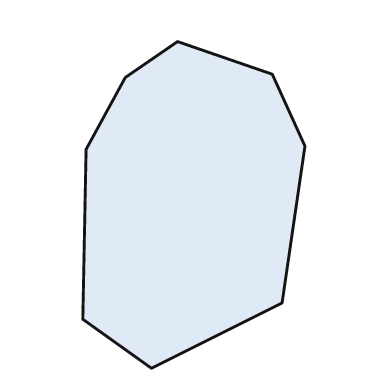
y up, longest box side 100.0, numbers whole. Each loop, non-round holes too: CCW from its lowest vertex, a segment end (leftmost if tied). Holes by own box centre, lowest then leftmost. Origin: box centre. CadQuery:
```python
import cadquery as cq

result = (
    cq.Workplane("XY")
    .moveTo(-13.0, -50.0)
    .lineTo(27.0, -30.0)
    .lineTo(34.0, 18.0)
    .lineTo(24.0, 40.0)
    .lineTo(-5.0, 50.0)
    .lineTo(-21.0, 39.0)
    .lineTo(-33.0, 17.0)
    .lineTo(-34.0, -35.0)
    .close()
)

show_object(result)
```